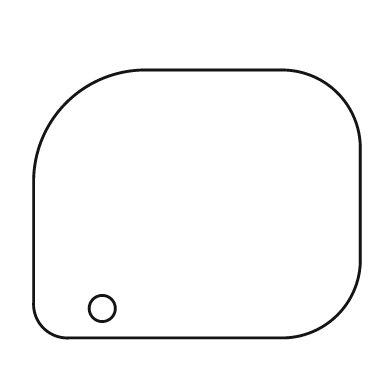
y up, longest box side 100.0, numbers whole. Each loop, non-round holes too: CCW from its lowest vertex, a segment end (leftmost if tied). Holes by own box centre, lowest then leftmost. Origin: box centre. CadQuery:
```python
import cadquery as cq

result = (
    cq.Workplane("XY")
    .moveTo(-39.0, -41.0)
    .lineTo(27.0, -41.0)
    .threePointArc((43.0, -34.0), (50.0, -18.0))
    .lineTo(50.0, 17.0)
    .threePointArc((43.0, 34.0), (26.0, 41.0))
    .lineTo(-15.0, 41.0)
    .threePointArc((-40.0, 31.0), (-50.0, 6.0))
    .lineTo(-50.0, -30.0)
    .threePointArc((-47.0, -38.0), (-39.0, -41.0))
    .close()
    .moveTo(-29.0, -32.0)
    .circle(4.0)
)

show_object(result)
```